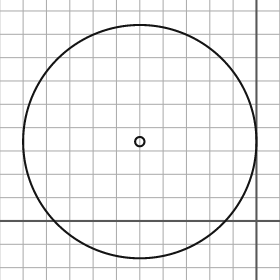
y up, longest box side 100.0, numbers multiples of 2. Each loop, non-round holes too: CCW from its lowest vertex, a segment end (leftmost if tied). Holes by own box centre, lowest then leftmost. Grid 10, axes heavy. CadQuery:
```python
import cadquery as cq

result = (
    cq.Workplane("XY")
    .moveTo(-50.0, 34.0)
    .circle(50.0)
    .moveTo(-50.0, 34.0)
    .circle(2.0)
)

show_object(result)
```